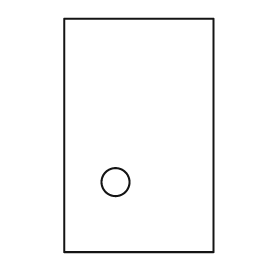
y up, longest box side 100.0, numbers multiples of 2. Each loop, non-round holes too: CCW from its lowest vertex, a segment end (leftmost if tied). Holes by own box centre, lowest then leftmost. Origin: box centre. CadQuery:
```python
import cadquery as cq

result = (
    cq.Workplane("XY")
    .moveTo(-32.0, -50.0)
    .lineTo(32.0, -50.0)
    .lineTo(32.0, 50.0)
    .lineTo(-32.0, 50.0)
    .close()
    .moveTo(-10.0, -20.0)
    .circle(6.0)
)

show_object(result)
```